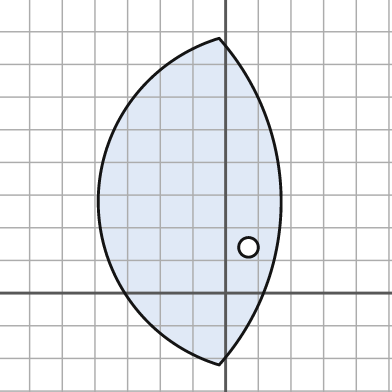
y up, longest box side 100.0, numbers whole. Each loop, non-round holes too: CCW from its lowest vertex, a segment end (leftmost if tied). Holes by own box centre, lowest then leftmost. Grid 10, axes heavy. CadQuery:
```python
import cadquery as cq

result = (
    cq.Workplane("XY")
    .moveTo(-2.0, -22.0)
    .threePointArc((17.0, 28.0), (-2.0, 78.0))
    .threePointArc((-39.0, 28.0), (-2.0, -22.0))
    .close()
    .moveTo(7.0, 14.0)
    .circle(3.0)
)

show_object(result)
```